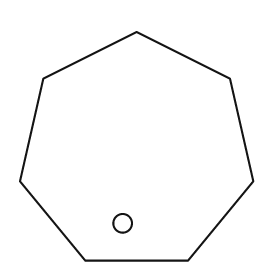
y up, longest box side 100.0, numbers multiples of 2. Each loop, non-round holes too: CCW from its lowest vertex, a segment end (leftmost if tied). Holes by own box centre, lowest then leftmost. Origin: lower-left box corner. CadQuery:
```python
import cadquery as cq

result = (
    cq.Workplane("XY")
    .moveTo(28.0, 0.0)
    .lineTo(72.0, 0.0)
    .lineTo(100.0, 34.0)
    .lineTo(90.0, 78.0)
    .lineTo(50.0, 98.0)
    .lineTo(10.0, 78.0)
    .lineTo(0.0, 34.0)
    .close()
    .moveTo(44.0, 16.0)
    .circle(4.0)
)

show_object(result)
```